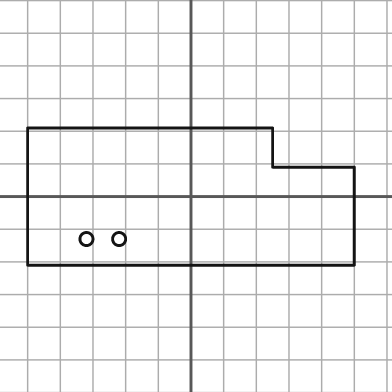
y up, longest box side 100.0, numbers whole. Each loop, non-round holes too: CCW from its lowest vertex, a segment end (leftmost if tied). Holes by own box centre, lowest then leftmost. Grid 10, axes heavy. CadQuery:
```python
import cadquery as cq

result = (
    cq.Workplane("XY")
    .moveTo(-50.0, -21.0)
    .lineTo(50.0, -21.0)
    .lineTo(50.0, 9.0)
    .lineTo(25.0, 9.0)
    .lineTo(25.0, 21.0)
    .lineTo(-50.0, 21.0)
    .close()
    .moveTo(-32.0, -13.0)
    .circle(2.0)
    .moveTo(-22.0, -13.0)
    .circle(2.0)
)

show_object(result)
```